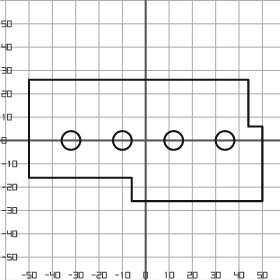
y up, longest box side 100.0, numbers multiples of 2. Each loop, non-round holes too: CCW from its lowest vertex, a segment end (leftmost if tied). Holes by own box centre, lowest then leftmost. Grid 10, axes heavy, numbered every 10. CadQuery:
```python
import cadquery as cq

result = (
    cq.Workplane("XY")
    .moveTo(-6.0, -26.0)
    .lineTo(50.0, -26.0)
    .lineTo(50.0, 6.0)
    .lineTo(44.0, 6.0)
    .lineTo(44.0, 26.0)
    .lineTo(-50.0, 26.0)
    .lineTo(-50.0, -16.0)
    .lineTo(-6.0, -16.0)
    .close()
    .moveTo(-32.0, 0.0)
    .circle(4.0)
    .moveTo(-10.0, 0.0)
    .circle(4.0)
    .moveTo(12.0, 0.0)
    .circle(4.0)
    .moveTo(34.0, 0.0)
    .circle(4.0)
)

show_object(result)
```